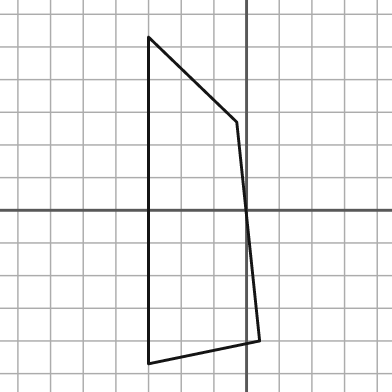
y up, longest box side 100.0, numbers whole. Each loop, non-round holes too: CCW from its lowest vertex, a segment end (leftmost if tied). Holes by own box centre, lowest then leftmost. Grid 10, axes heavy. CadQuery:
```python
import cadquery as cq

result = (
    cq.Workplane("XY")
    .moveTo(-30.0, -47.0)
    .lineTo(4.0, -40.0)
    .lineTo(-3.0, 27.0)
    .lineTo(-30.0, 53.0)
    .close()
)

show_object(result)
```